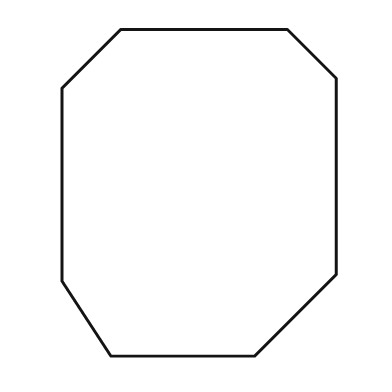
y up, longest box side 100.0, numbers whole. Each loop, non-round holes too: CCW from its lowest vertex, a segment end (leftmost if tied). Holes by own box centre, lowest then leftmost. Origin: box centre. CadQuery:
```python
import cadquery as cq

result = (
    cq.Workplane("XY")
    .moveTo(-27.0, -50.0)
    .lineTo(17.0, -50.0)
    .lineTo(42.0, -25.0)
    .lineTo(42.0, 35.0)
    .lineTo(27.0, 50.0)
    .lineTo(-24.0, 50.0)
    .lineTo(-42.0, 32.0)
    .lineTo(-42.0, -27.0)
    .close()
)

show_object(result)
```